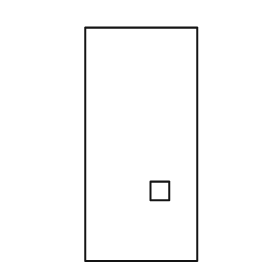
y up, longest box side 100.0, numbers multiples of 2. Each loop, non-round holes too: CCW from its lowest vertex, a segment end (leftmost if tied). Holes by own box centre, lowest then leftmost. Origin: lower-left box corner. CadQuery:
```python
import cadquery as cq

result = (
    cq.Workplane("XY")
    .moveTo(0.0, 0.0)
    .lineTo(48.0, 0.0)
    .lineTo(48.0, 100.0)
    .lineTo(0.0, 100.0)
    .close()
    .moveTo(28.0, 26.0)
    .lineTo(36.0, 26.0)
    .lineTo(36.0, 34.0)
    .lineTo(28.0, 34.0)
    .close()
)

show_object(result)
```